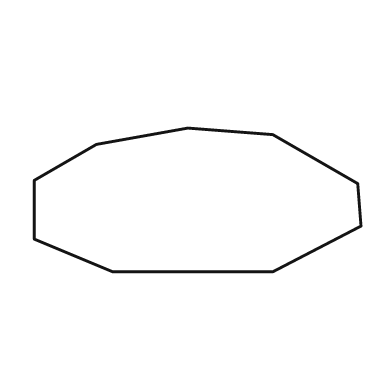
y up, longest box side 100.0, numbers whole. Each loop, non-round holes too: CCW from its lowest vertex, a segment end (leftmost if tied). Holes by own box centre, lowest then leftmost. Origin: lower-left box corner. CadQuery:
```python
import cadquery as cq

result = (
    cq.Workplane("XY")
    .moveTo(24.0, 0.0)
    .lineTo(73.0, 0.0)
    .lineTo(100.0, 14.0)
    .lineTo(99.0, 27.0)
    .lineTo(73.0, 42.0)
    .lineTo(47.0, 44.0)
    .lineTo(19.0, 39.0)
    .lineTo(0.0, 28.0)
    .lineTo(0.0, 10.0)
    .close()
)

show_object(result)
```